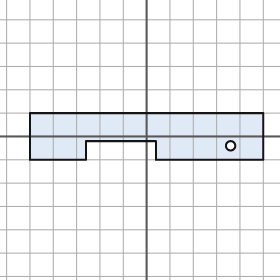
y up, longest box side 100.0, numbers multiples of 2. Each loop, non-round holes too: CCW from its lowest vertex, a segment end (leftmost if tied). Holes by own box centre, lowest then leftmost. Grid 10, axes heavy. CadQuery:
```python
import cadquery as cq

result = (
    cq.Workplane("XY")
    .moveTo(-50.0, -10.0)
    .lineTo(-26.0, -10.0)
    .lineTo(-26.0, -2.0)
    .lineTo(4.0, -2.0)
    .lineTo(4.0, -10.0)
    .lineTo(50.0, -10.0)
    .lineTo(50.0, 10.0)
    .lineTo(-50.0, 10.0)
    .close()
    .moveTo(36.0, -4.0)
    .circle(2.0)
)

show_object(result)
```